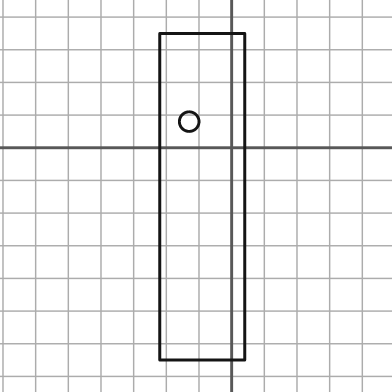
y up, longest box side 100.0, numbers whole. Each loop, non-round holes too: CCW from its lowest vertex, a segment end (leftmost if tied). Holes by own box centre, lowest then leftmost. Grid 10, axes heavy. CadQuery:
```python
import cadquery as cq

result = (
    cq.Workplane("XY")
    .moveTo(-22.0, -65.0)
    .lineTo(4.0, -65.0)
    .lineTo(4.0, 35.0)
    .lineTo(-22.0, 35.0)
    .close()
    .moveTo(-13.0, 8.0)
    .circle(3.0)
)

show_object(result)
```